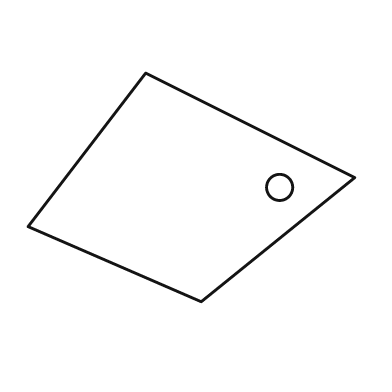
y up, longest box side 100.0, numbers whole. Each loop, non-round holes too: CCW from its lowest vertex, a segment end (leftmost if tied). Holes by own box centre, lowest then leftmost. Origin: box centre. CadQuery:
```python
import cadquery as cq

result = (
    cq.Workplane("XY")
    .moveTo(3.0, -35.0)
    .lineTo(50.0, 3.0)
    .lineTo(-14.0, 35.0)
    .lineTo(-50.0, -12.0)
    .close()
    .moveTo(27.0, 0.0)
    .circle(4.0)
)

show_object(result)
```